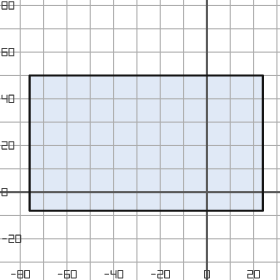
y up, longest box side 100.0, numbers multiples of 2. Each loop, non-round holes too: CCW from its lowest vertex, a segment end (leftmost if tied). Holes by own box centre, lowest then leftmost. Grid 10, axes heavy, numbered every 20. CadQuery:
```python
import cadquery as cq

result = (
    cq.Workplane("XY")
    .moveTo(-76.0, -8.0)
    .lineTo(24.0, -8.0)
    .lineTo(24.0, 50.0)
    .lineTo(-76.0, 50.0)
    .close()
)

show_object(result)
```